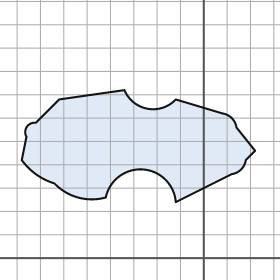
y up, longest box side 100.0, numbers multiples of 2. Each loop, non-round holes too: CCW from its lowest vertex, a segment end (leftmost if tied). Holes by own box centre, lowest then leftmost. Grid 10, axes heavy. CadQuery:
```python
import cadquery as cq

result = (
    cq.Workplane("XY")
    .moveTo(-12.0, 24.0)
    .lineTo(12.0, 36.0)
    .threePointArc((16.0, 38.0), (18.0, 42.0))
    .lineTo(22.0, 46.0)
    .lineTo(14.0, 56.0)
    .threePointArc((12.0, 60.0), (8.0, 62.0))
    .lineTo(-12.0, 68.0)
    .threePointArc((-24.0, 64.0), (-34.0, 72.0))
    .lineTo(-62.0, 68.0)
    .lineTo(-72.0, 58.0)
    .threePointArc((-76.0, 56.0), (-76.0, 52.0))
    .lineTo(-78.0, 42.0)
    .threePointArc((-72.0, 36.0), (-64.0, 32.0))
    .threePointArc((-54.0, 26.0), (-42.0, 26.0))
    .threePointArc((-26.0, 38.0), (-12.0, 24.0))
    .close()
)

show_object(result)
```